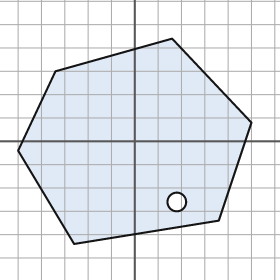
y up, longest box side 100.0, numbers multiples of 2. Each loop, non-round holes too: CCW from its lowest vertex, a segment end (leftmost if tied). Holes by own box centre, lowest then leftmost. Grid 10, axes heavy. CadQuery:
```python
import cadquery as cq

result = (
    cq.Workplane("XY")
    .moveTo(-26.0, -44.0)
    .lineTo(36.0, -34.0)
    .lineTo(50.0, 8.0)
    .lineTo(16.0, 44.0)
    .lineTo(-34.0, 30.0)
    .lineTo(-50.0, -4.0)
    .close()
    .moveTo(18.0, -26.0)
    .circle(4.0)
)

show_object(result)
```